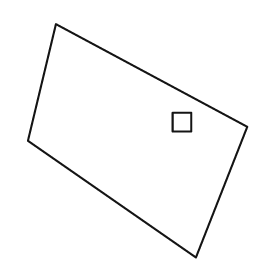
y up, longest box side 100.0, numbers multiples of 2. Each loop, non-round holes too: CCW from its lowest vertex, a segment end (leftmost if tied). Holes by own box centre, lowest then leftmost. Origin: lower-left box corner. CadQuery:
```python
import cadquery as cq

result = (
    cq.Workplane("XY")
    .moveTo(72.0, 0.0)
    .lineTo(94.0, 56.0)
    .lineTo(12.0, 100.0)
    .lineTo(0.0, 50.0)
    .close()
    .moveTo(62.0, 54.0)
    .lineTo(70.0, 54.0)
    .lineTo(70.0, 62.0)
    .lineTo(62.0, 62.0)
    .close()
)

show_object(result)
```